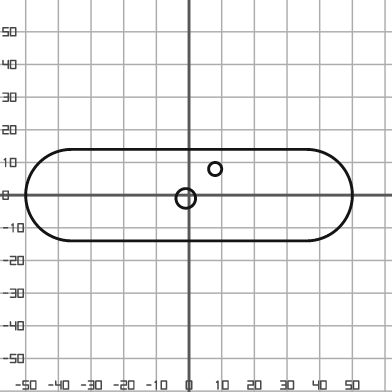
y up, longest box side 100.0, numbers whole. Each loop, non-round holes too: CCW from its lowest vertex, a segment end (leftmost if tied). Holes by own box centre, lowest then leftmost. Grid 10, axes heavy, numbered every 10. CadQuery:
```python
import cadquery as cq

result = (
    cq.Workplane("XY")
    .moveTo(-36.0, -14.0)
    .lineTo(36.0, -14.0)
    .threePointArc((50.0, 0.0), (36.0, 14.0))
    .lineTo(-36.0, 14.0)
    .threePointArc((-50.0, 0.0), (-36.0, -14.0))
    .close()
    .moveTo(-1.0, -1.0)
    .circle(3.0)
    .moveTo(8.0, 8.0)
    .circle(2.0)
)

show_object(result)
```